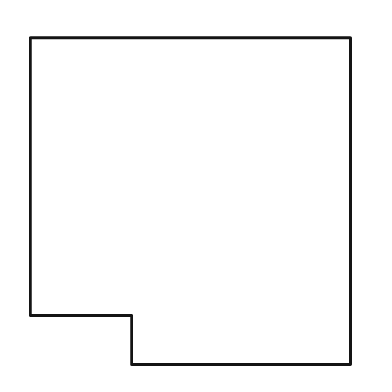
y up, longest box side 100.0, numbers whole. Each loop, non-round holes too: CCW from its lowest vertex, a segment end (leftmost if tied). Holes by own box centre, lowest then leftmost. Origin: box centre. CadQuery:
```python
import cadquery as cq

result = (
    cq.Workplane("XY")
    .moveTo(-18.0, -50.0)
    .lineTo(49.0, -50.0)
    .lineTo(49.0, 50.0)
    .lineTo(-49.0, 50.0)
    .lineTo(-49.0, -35.0)
    .lineTo(-18.0, -35.0)
    .close()
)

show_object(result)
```